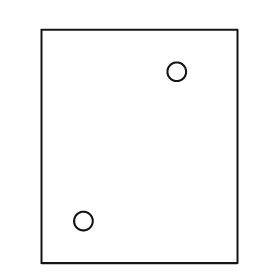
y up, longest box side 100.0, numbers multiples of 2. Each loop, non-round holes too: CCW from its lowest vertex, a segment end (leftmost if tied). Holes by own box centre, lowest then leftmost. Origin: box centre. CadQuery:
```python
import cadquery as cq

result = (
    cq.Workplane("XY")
    .moveTo(-42.0, -50.0)
    .lineTo(42.0, -50.0)
    .lineTo(42.0, 50.0)
    .lineTo(-42.0, 50.0)
    .close()
    .moveTo(-24.0, -32.0)
    .circle(4.0)
    .moveTo(16.0, 32.0)
    .circle(4.0)
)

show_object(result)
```